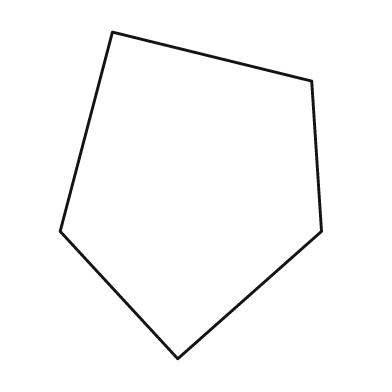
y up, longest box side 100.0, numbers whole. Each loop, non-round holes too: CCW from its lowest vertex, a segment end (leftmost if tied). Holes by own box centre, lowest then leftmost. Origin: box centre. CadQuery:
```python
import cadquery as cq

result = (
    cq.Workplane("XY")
    .moveTo(-4.0, -50.0)
    .lineTo(40.0, -11.0)
    .lineTo(37.0, 35.0)
    .lineTo(-24.0, 50.0)
    .lineTo(-40.0, -11.0)
    .close()
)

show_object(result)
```